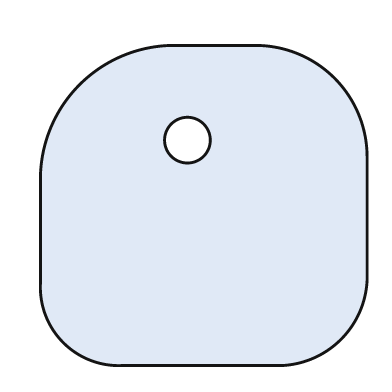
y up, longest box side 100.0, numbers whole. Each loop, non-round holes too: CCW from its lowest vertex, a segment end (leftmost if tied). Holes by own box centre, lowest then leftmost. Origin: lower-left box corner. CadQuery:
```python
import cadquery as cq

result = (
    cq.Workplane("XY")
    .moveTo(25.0, 0.0)
    .lineTo(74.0, 0.0)
    .threePointArc((92.0, 8.0), (100.0, 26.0))
    .lineTo(100.0, 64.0)
    .threePointArc((90.0, 88.0), (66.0, 98.0))
    .lineTo(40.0, 98.0)
    .threePointArc((12.0, 86.0), (0.0, 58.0))
    .lineTo(0.0, 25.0)
    .threePointArc((7.0, 7.0), (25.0, 0.0))
    .close()
    .moveTo(45.0, 69.0)
    .circle(7.0)
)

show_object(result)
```